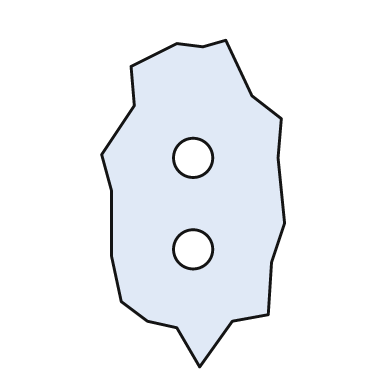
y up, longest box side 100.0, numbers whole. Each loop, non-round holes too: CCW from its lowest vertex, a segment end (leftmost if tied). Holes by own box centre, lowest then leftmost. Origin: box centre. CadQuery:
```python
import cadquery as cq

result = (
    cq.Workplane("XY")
    .moveTo(2.0, -50.0)
    .lineTo(12.0, -36.0)
    .lineTo(23.0, -34.0)
    .lineTo(24.0, -18.0)
    .lineTo(28.0, -6.0)
    .lineTo(26.0, 14.0)
    .lineTo(27.0, 26.0)
    .lineTo(18.0, 33.0)
    .lineTo(10.0, 50.0)
    .lineTo(3.0, 48.0)
    .lineTo(-5.0, 49.0)
    .lineTo(-19.0, 42.0)
    .lineTo(-18.0, 30.0)
    .lineTo(-28.0, 15.0)
    .lineTo(-25.0, 4.0)
    .lineTo(-25.0, -16.0)
    .lineTo(-22.0, -30.0)
    .lineTo(-14.0, -36.0)
    .lineTo(-5.0, -38.0)
    .close()
    .moveTo(0.0, -14.0)
    .circle(6.0)
    .moveTo(0.0, 14.0)
    .circle(6.0)
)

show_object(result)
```